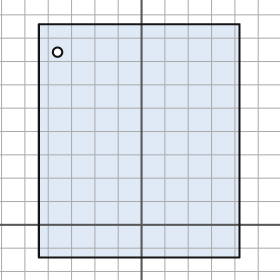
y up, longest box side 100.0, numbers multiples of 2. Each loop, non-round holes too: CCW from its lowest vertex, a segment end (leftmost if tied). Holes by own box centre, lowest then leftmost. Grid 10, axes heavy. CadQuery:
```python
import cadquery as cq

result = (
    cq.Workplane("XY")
    .moveTo(-44.0, -14.0)
    .lineTo(42.0, -14.0)
    .lineTo(42.0, 86.0)
    .lineTo(-44.0, 86.0)
    .close()
    .moveTo(-36.0, 74.0)
    .circle(2.0)
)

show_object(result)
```